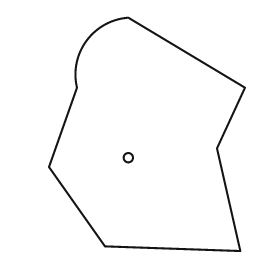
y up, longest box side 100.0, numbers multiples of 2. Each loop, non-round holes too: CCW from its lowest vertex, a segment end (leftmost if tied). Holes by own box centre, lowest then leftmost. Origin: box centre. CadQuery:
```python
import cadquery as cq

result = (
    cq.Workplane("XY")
    .moveTo(40.0, -50.0)
    .lineTo(30.0, -6.0)
    .lineTo(42.0, 20.0)
    .lineTo(-8.0, 50.0)
    .threePointArc((-26.0, 40.0), (-30.0, 20.0))
    .lineTo(-42.0, -14.0)
    .lineTo(-18.0, -48.0)
    .close()
    .moveTo(-8.0, -10.0)
    .circle(2.0)
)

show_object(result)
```